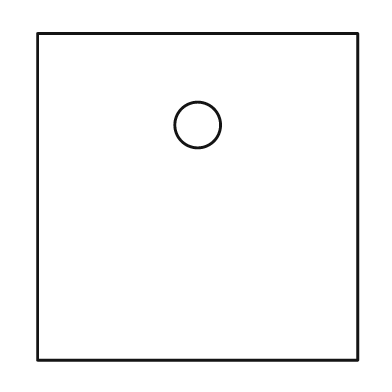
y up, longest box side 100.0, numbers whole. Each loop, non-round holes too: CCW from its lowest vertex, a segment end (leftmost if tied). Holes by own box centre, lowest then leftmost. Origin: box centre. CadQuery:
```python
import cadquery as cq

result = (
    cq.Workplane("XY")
    .moveTo(-49.0, -50.0)
    .lineTo(49.0, -50.0)
    .lineTo(49.0, 50.0)
    .lineTo(-49.0, 50.0)
    .close()
    .moveTo(0.0, 22.0)
    .circle(7.0)
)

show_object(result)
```